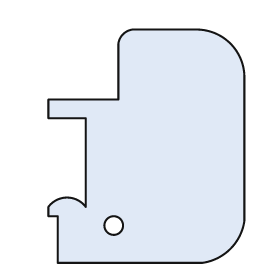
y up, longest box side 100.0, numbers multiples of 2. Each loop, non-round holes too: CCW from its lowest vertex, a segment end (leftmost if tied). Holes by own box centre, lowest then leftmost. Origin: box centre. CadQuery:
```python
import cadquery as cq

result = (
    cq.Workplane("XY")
    .moveTo(-38.0, -50.0)
    .lineTo(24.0, -50.0)
    .threePointArc((36.0, -44.0), (42.0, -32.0))
    .lineTo(42.0, 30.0)
    .threePointArc((36.0, 44.0), (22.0, 50.0))
    .lineTo(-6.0, 50.0)
    .threePointArc((-10.0, 48.0), (-12.0, 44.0))
    .lineTo(-12.0, 20.0)
    .lineTo(-42.0, 20.0)
    .lineTo(-42.0, 12.0)
    .lineTo(-26.0, 12.0)
    .lineTo(-26.0, -26.0)
    .threePointArc((-34.0, -22.0), (-42.0, -26.0))
    .lineTo(-42.0, -30.0)
    .lineTo(-38.0, -30.0)
    .close()
    .moveTo(-14.0, -34.0)
    .circle(4.0)
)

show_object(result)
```